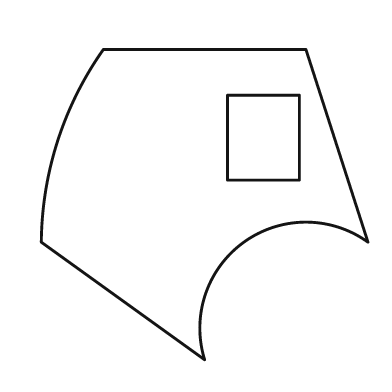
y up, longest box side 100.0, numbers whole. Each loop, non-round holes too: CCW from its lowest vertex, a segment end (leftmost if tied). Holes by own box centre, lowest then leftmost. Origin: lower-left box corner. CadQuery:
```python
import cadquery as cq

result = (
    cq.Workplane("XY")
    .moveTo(50.0, 0.0)
    .threePointArc((62.0, 36.0), (100.0, 36.0))
    .lineTo(81.0, 95.0)
    .lineTo(19.0, 95.0)
    .threePointArc((5.0, 67.0), (0.0, 36.0))
    .close()
    .moveTo(57.0, 55.0)
    .lineTo(79.0, 55.0)
    .lineTo(79.0, 81.0)
    .lineTo(57.0, 81.0)
    .close()
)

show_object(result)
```